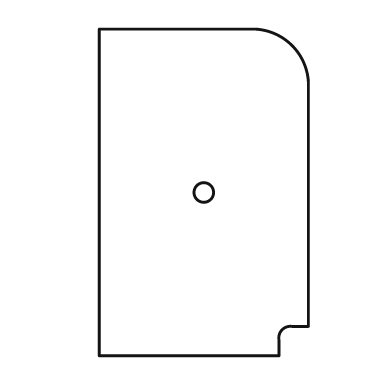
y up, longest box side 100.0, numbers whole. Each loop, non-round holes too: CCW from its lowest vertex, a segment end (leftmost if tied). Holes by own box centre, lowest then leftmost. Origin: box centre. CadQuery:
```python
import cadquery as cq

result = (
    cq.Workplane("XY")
    .moveTo(-32.0, -50.0)
    .lineTo(23.0, -50.0)
    .lineTo(23.0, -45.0)
    .threePointArc((24.0, -42.0), (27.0, -41.0))
    .lineTo(32.0, -41.0)
    .lineTo(32.0, 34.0)
    .threePointArc((27.0, 45.0), (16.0, 50.0))
    .lineTo(-32.0, 50.0)
    .close()
    .moveTo(0.0, 0.0)
    .circle(3.0)
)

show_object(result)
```